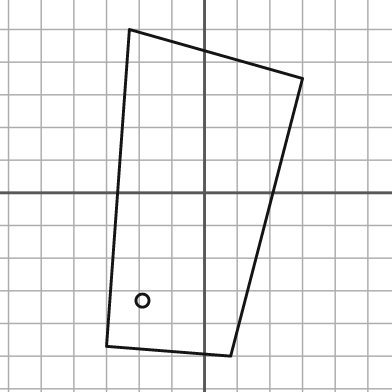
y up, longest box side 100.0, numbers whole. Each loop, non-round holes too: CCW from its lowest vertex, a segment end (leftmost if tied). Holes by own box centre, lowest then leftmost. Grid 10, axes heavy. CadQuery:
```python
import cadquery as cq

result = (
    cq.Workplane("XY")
    .moveTo(8.0, -50.0)
    .lineTo(30.0, 35.0)
    .lineTo(-23.0, 50.0)
    .lineTo(-30.0, -47.0)
    .close()
    .moveTo(-19.0, -33.0)
    .circle(2.0)
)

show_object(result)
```